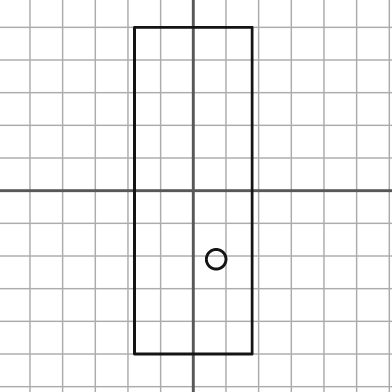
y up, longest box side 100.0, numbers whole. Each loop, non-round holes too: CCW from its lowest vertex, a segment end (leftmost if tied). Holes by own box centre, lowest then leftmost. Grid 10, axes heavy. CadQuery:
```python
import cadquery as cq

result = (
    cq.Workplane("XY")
    .moveTo(-18.0, -50.0)
    .lineTo(18.0, -50.0)
    .lineTo(18.0, 50.0)
    .lineTo(-18.0, 50.0)
    .close()
    .moveTo(7.0, -21.0)
    .circle(3.0)
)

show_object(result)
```